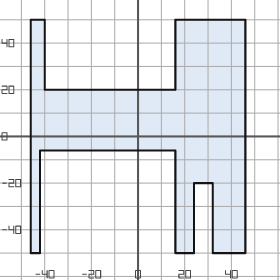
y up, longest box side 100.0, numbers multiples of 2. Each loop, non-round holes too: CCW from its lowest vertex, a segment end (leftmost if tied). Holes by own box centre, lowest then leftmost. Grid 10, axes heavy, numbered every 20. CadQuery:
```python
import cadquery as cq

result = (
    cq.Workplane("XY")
    .moveTo(-46.0, -50.0)
    .lineTo(-42.0, -50.0)
    .lineTo(-42.0, -6.0)
    .lineTo(16.0, -6.0)
    .lineTo(16.0, -50.0)
    .lineTo(24.0, -50.0)
    .lineTo(24.0, -20.0)
    .lineTo(32.0, -20.0)
    .lineTo(32.0, -50.0)
    .lineTo(46.0, -50.0)
    .lineTo(46.0, 50.0)
    .lineTo(16.0, 50.0)
    .lineTo(16.0, 20.0)
    .lineTo(-40.0, 20.0)
    .lineTo(-40.0, 50.0)
    .lineTo(-46.0, 50.0)
    .close()
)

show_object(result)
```